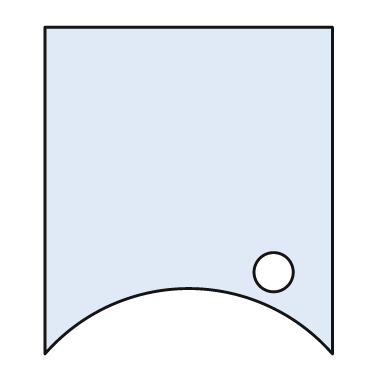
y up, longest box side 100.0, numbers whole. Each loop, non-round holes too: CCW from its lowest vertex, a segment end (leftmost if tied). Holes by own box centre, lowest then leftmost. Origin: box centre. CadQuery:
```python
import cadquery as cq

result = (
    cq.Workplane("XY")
    .moveTo(-44.0, -50.0)
    .threePointArc((0.0, -30.0), (44.0, -50.0))
    .lineTo(44.0, 50.0)
    .lineTo(-44.0, 50.0)
    .close()
    .moveTo(26.0, -25.0)
    .circle(6.0)
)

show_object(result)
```